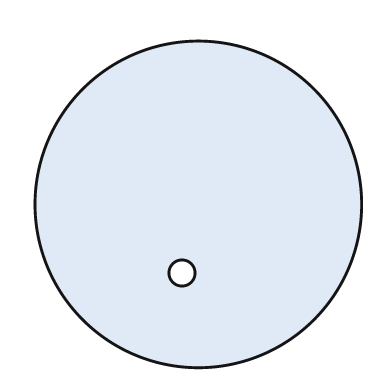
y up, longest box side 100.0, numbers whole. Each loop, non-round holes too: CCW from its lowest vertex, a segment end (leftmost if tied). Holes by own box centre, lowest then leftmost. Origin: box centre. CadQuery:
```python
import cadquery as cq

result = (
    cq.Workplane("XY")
    .moveTo(0.0, 0.0)
    .circle(50.0)
    .moveTo(-5.0, -21.0)
    .circle(4.0)
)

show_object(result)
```